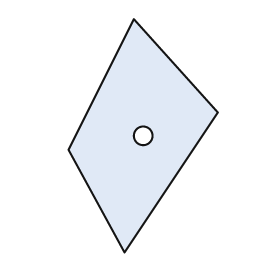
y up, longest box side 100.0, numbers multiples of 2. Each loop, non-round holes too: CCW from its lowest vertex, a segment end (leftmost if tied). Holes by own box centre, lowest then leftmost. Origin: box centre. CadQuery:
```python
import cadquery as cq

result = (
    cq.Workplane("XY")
    .moveTo(-8.0, -50.0)
    .lineTo(32.0, 10.0)
    .lineTo(-4.0, 50.0)
    .lineTo(-32.0, -6.0)
    .close()
    .moveTo(0.0, 0.0)
    .circle(4.0)
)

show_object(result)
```